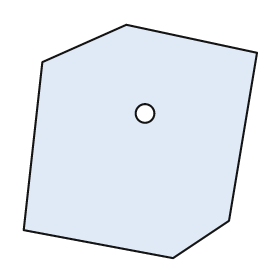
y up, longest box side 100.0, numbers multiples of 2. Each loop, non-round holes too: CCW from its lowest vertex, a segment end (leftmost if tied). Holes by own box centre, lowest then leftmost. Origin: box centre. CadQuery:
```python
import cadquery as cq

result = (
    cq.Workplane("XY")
    .moveTo(14.0, -50.0)
    .lineTo(38.0, -34.0)
    .lineTo(50.0, 38.0)
    .lineTo(-6.0, 50.0)
    .lineTo(-42.0, 34.0)
    .lineTo(-50.0, -38.0)
    .close()
    .moveTo(2.0, 12.0)
    .circle(4.0)
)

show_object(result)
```